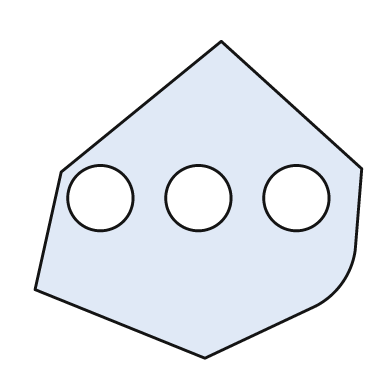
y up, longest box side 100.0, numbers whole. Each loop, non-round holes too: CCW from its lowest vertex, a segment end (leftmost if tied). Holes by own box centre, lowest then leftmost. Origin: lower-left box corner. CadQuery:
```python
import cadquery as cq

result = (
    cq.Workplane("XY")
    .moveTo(52.0, 0.0)
    .lineTo(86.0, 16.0)
    .threePointArc((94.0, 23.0), (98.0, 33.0))
    .lineTo(100.0, 58.0)
    .lineTo(57.0, 97.0)
    .lineTo(8.0, 57.0)
    .lineTo(0.0, 21.0)
    .close()
    .moveTo(20.0, 49.0)
    .circle(10.0)
    .moveTo(50.0, 49.0)
    .circle(10.0)
    .moveTo(80.0, 49.0)
    .circle(10.0)
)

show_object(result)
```